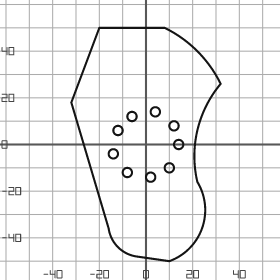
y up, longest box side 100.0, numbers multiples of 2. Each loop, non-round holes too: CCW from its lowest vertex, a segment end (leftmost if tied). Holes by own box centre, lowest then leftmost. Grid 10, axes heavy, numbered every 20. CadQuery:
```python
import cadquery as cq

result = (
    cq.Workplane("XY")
    .moveTo(10.0, -50.0)
    .threePointArc((24.0, -36.0), (22.0, -16.0))
    .threePointArc((22.0, 6.0), (32.0, 26.0))
    .threePointArc((22.0, 40.0), (8.0, 50.0))
    .lineTo(-20.0, 50.0)
    .lineTo(-32.0, 18.0)
    .lineTo(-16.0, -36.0)
    .threePointArc((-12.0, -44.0), (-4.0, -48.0))
    .close()
    .moveTo(2.0, -14.0)
    .circle(2.0)
    .moveTo(-8.0, -12.0)
    .circle(2.0)
    .moveTo(10.0, -10.0)
    .circle(2.0)
    .moveTo(-14.0, -4.0)
    .circle(2.0)
    .moveTo(14.0, 0.0)
    .circle(2.0)
    .moveTo(-12.0, 6.0)
    .circle(2.0)
    .moveTo(12.0, 8.0)
    .circle(2.0)
    .moveTo(-6.0, 12.0)
    .circle(2.0)
    .moveTo(4.0, 14.0)
    .circle(2.0)
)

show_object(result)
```